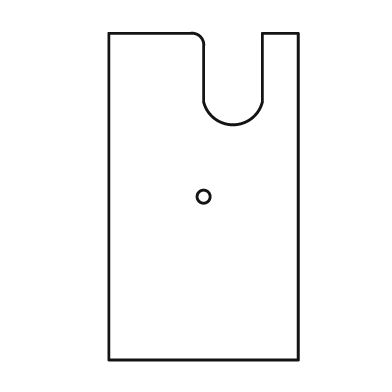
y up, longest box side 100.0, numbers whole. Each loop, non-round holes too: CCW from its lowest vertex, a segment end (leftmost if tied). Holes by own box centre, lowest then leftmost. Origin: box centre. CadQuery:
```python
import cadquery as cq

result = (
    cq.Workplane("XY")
    .moveTo(-29.0, -50.0)
    .lineTo(29.0, -50.0)
    .lineTo(29.0, 50.0)
    .lineTo(18.0, 50.0)
    .lineTo(18.0, 29.0)
    .threePointArc((9.0, 22.0), (0.0, 29.0))
    .lineTo(0.0, 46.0)
    .threePointArc((-1.0, 49.0), (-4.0, 50.0))
    .lineTo(-29.0, 50.0)
    .close()
    .moveTo(0.0, 0.0)
    .circle(2.0)
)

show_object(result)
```